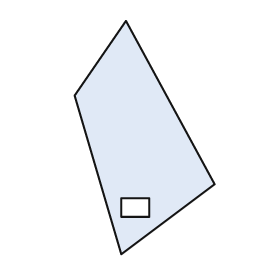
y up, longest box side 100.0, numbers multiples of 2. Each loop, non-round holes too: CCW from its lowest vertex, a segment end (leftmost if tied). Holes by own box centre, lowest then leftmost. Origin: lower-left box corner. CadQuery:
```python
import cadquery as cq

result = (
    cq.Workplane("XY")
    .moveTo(20.0, 0.0)
    .lineTo(60.0, 30.0)
    .lineTo(22.0, 100.0)
    .lineTo(0.0, 68.0)
    .close()
    .moveTo(20.0, 16.0)
    .lineTo(32.0, 16.0)
    .lineTo(32.0, 24.0)
    .lineTo(20.0, 24.0)
    .close()
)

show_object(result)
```